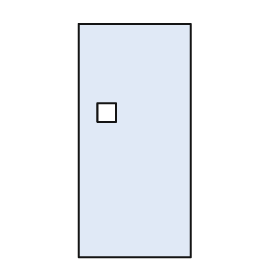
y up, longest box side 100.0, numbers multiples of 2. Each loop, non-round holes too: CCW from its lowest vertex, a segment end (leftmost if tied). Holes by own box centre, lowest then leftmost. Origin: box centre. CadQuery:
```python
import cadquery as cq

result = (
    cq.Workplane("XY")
    .moveTo(-24.0, -50.0)
    .lineTo(24.0, -50.0)
    .lineTo(24.0, 50.0)
    .lineTo(-24.0, 50.0)
    .close()
    .moveTo(-16.0, 8.0)
    .lineTo(-8.0, 8.0)
    .lineTo(-8.0, 16.0)
    .lineTo(-16.0, 16.0)
    .close()
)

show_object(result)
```